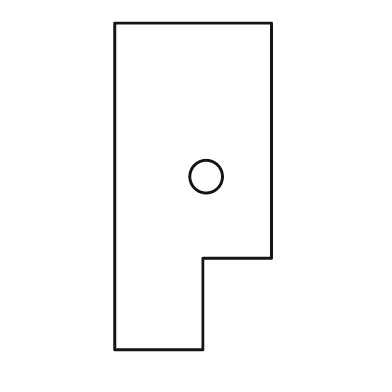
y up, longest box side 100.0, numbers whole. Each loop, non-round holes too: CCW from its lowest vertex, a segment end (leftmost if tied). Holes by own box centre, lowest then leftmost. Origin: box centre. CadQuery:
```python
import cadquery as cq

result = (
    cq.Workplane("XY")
    .moveTo(-24.0, -50.0)
    .lineTo(3.0, -50.0)
    .lineTo(3.0, -22.0)
    .lineTo(24.0, -22.0)
    .lineTo(24.0, 50.0)
    .lineTo(-24.0, 50.0)
    .close()
    .moveTo(4.0, 3.0)
    .circle(5.0)
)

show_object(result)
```